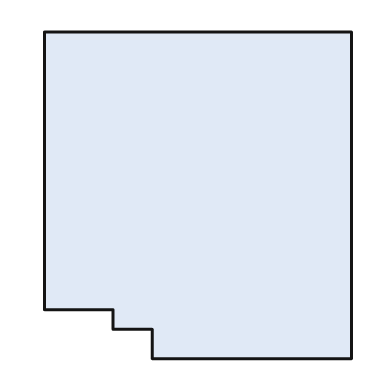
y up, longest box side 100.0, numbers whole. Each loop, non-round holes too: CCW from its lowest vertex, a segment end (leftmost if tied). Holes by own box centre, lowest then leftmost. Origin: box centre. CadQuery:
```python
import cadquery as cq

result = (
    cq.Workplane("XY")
    .moveTo(-14.0, -50.0)
    .lineTo(47.0, -50.0)
    .lineTo(47.0, 50.0)
    .lineTo(-47.0, 50.0)
    .lineTo(-47.0, -35.0)
    .lineTo(-26.0, -35.0)
    .lineTo(-26.0, -41.0)
    .lineTo(-14.0, -41.0)
    .close()
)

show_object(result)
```